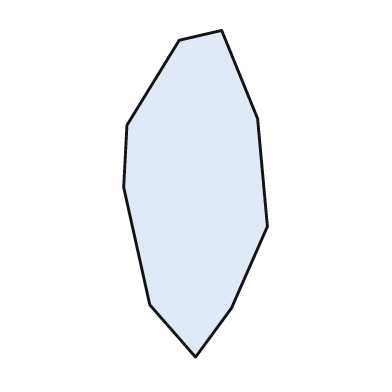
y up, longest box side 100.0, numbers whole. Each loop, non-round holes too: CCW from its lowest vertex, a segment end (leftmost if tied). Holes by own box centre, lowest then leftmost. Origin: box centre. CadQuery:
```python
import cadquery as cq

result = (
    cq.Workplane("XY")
    .moveTo(0.0, -50.0)
    .lineTo(11.0, -35.0)
    .lineTo(22.0, -10.0)
    .lineTo(19.0, 23.0)
    .lineTo(8.0, 50.0)
    .lineTo(-5.0, 47.0)
    .lineTo(-21.0, 21.0)
    .lineTo(-22.0, 2.0)
    .lineTo(-14.0, -34.0)
    .close()
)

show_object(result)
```